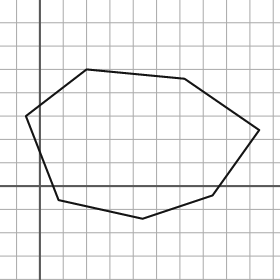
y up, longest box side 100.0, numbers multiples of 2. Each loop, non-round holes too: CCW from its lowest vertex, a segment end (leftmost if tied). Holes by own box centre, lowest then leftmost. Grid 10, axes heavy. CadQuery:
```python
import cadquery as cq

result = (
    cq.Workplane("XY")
    .moveTo(44.0, -14.0)
    .lineTo(74.0, -4.0)
    .lineTo(94.0, 24.0)
    .lineTo(62.0, 46.0)
    .lineTo(20.0, 50.0)
    .lineTo(-6.0, 30.0)
    .lineTo(8.0, -6.0)
    .close()
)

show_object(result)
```